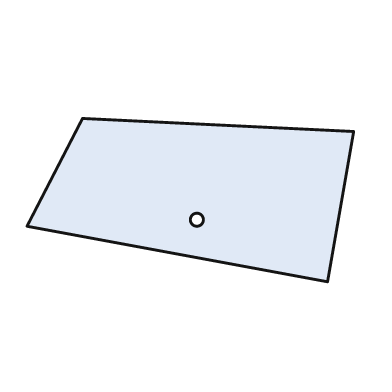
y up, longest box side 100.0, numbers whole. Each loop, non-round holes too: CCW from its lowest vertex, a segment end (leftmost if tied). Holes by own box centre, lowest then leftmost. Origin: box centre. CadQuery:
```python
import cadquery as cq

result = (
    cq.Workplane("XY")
    .moveTo(42.0, -25.0)
    .lineTo(50.0, 21.0)
    .lineTo(-33.0, 25.0)
    .lineTo(-50.0, -8.0)
    .close()
    .moveTo(2.0, -6.0)
    .circle(2.0)
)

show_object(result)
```